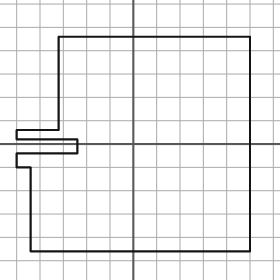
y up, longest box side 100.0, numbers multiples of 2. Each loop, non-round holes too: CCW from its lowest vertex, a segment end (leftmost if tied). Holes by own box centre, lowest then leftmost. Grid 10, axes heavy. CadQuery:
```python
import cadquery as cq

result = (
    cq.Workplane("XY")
    .moveTo(-44.0, -46.0)
    .lineTo(50.0, -46.0)
    .lineTo(50.0, 46.0)
    .lineTo(-32.0, 46.0)
    .lineTo(-32.0, 6.0)
    .lineTo(-50.0, 6.0)
    .lineTo(-50.0, 2.0)
    .lineTo(-24.0, 2.0)
    .lineTo(-24.0, -4.0)
    .lineTo(-50.0, -4.0)
    .lineTo(-50.0, -10.0)
    .lineTo(-44.0, -10.0)
    .close()
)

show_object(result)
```